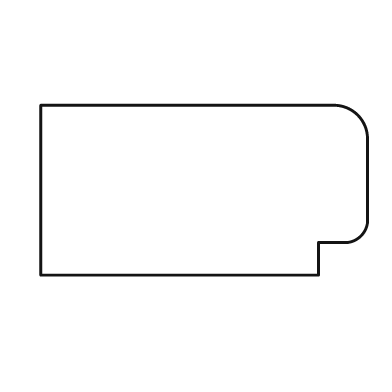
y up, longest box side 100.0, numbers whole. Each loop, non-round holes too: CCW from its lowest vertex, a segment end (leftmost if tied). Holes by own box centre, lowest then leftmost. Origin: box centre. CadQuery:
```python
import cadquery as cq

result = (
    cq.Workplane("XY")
    .moveTo(-50.0, -26.0)
    .lineTo(35.0, -26.0)
    .lineTo(35.0, -16.0)
    .lineTo(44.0, -16.0)
    .threePointArc((48.0, -14.0), (50.0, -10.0))
    .lineTo(50.0, 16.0)
    .threePointArc((47.0, 23.0), (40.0, 26.0))
    .lineTo(-50.0, 26.0)
    .close()
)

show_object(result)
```